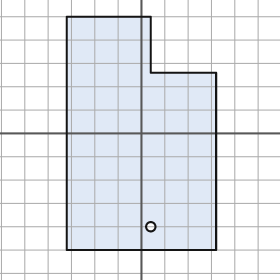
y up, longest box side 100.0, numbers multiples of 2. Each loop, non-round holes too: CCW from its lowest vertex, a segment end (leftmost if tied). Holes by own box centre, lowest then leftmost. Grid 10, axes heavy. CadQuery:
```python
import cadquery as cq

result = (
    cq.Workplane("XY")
    .moveTo(-32.0, -50.0)
    .lineTo(32.0, -50.0)
    .lineTo(32.0, 26.0)
    .lineTo(4.0, 26.0)
    .lineTo(4.0, 50.0)
    .lineTo(-32.0, 50.0)
    .close()
    .moveTo(4.0, -40.0)
    .circle(2.0)
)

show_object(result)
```